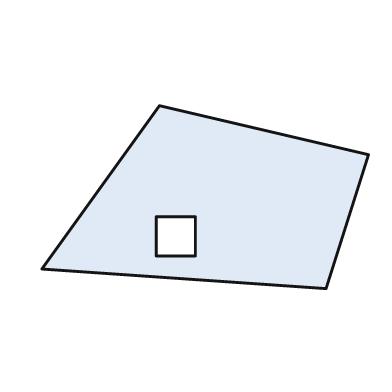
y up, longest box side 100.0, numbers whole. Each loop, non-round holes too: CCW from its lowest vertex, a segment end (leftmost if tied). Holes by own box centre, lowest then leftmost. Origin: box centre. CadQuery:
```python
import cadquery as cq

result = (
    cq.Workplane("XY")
    .moveTo(37.0, -28.0)
    .lineTo(50.0, 13.0)
    .lineTo(-14.0, 28.0)
    .lineTo(-50.0, -22.0)
    .close()
    .moveTo(-15.0, -18.0)
    .lineTo(-3.0, -18.0)
    .lineTo(-3.0, -6.0)
    .lineTo(-15.0, -6.0)
    .close()
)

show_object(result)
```